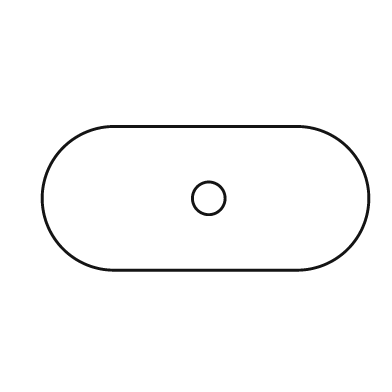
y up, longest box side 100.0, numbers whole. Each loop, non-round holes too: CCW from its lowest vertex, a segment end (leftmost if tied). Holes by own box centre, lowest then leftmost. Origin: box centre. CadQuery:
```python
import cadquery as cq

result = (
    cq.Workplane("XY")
    .moveTo(-28.0, -22.0)
    .lineTo(28.0, -22.0)
    .threePointArc((50.0, 0.0), (28.0, 22.0))
    .lineTo(-28.0, 22.0)
    .threePointArc((-50.0, 0.0), (-28.0, -22.0))
    .close()
    .moveTo(1.0, 0.0)
    .circle(5.0)
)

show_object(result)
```